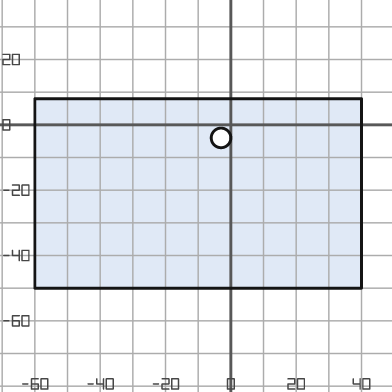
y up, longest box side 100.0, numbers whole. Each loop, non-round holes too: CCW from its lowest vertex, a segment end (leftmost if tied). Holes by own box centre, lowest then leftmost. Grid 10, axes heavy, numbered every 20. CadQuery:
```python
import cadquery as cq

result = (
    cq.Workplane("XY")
    .moveTo(-60.0, -50.0)
    .lineTo(40.0, -50.0)
    .lineTo(40.0, 8.0)
    .lineTo(-60.0, 8.0)
    .close()
    .moveTo(-3.0, -4.0)
    .circle(3.0)
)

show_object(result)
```